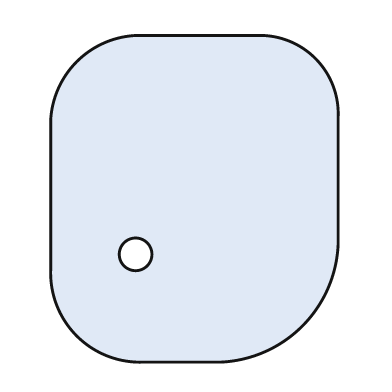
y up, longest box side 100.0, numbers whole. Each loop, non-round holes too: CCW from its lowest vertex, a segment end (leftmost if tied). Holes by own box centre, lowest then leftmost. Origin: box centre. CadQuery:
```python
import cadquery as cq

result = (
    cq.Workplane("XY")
    .moveTo(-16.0, -50.0)
    .lineTo(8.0, -50.0)
    .threePointArc((33.0, -39.0), (44.0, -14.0))
    .lineTo(44.0, 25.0)
    .threePointArc((37.0, 43.0), (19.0, 50.0))
    .lineTo(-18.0, 50.0)
    .threePointArc((-36.0, 42.0), (-44.0, 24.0))
    .lineTo(-44.0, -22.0)
    .threePointArc((-36.0, -42.0), (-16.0, -50.0))
    .close()
    .moveTo(-18.0, -17.0)
    .circle(5.0)
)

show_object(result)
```